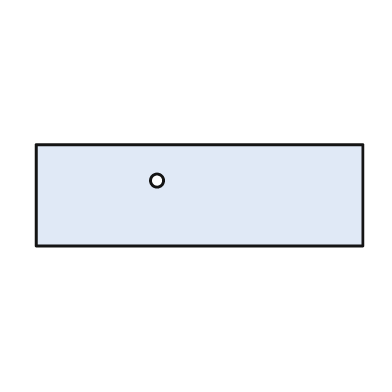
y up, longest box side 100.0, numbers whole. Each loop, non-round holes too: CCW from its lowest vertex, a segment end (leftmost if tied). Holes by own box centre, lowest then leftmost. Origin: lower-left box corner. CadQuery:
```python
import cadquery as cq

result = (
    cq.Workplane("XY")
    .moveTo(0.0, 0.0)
    .lineTo(100.0, 0.0)
    .lineTo(100.0, 31.0)
    .lineTo(0.0, 31.0)
    .close()
    .moveTo(37.0, 20.0)
    .circle(2.0)
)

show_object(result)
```